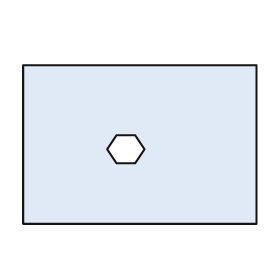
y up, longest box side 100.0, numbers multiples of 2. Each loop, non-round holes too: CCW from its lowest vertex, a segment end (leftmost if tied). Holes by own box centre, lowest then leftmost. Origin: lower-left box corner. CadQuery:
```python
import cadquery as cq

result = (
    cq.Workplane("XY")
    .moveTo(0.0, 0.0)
    .lineTo(100.0, 0.0)
    .lineTo(100.0, 68.0)
    .lineTo(0.0, 68.0)
    .close()
    .moveTo(40.0, 26.0)
    .lineTo(48.0, 26.0)
    .lineTo(52.0, 32.0)
    .lineTo(48.0, 38.0)
    .lineTo(40.0, 38.0)
    .lineTo(36.0, 32.0)
    .close()
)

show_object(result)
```